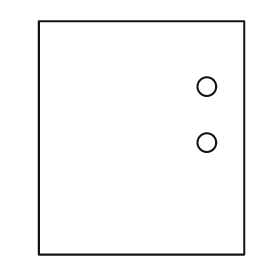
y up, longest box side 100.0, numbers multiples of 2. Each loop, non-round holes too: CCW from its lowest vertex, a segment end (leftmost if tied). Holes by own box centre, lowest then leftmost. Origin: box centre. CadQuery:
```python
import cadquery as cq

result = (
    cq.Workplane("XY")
    .moveTo(-44.0, -50.0)
    .lineTo(44.0, -50.0)
    .lineTo(44.0, 50.0)
    .lineTo(-44.0, 50.0)
    .close()
    .moveTo(28.0, -2.0)
    .circle(4.0)
    .moveTo(28.0, 22.0)
    .circle(4.0)
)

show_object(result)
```